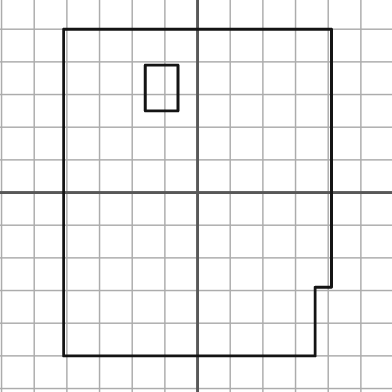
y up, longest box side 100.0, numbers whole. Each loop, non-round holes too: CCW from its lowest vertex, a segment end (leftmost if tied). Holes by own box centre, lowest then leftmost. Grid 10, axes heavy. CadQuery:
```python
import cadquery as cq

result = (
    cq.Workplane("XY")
    .moveTo(-41.0, -50.0)
    .lineTo(36.0, -50.0)
    .lineTo(36.0, -29.0)
    .lineTo(41.0, -29.0)
    .lineTo(41.0, 50.0)
    .lineTo(-41.0, 50.0)
    .close()
    .moveTo(-16.0, 25.0)
    .lineTo(-6.0, 25.0)
    .lineTo(-6.0, 39.0)
    .lineTo(-16.0, 39.0)
    .close()
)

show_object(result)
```